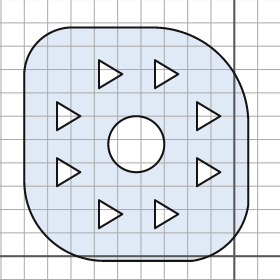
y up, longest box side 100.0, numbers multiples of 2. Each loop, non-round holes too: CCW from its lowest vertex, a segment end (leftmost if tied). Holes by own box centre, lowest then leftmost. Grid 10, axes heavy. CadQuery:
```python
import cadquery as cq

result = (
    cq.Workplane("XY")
    .moveTo(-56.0, -2.0)
    .lineTo(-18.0, -2.0)
    .threePointArc((-2.0, 6.0), (6.0, 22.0))
    .lineTo(6.0, 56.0)
    .threePointArc((-6.0, 86.0), (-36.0, 98.0))
    .lineTo(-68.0, 98.0)
    .threePointArc((-84.0, 92.0), (-90.0, 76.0))
    .lineTo(-90.0, 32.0)
    .threePointArc((-80.0, 8.0), (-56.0, -2.0))
    .close()
    .moveTo(-58.0, 12.0)
    .lineTo(-48.0, 18.0)
    .lineTo(-58.0, 24.0)
    .close()
    .moveTo(-34.0, 12.0)
    .lineTo(-24.0, 18.0)
    .lineTo(-34.0, 24.0)
    .close()
    .moveTo(-76.0, 30.0)
    .lineTo(-66.0, 36.0)
    .lineTo(-76.0, 42.0)
    .close()
    .moveTo(-16.0, 30.0)
    .lineTo(-6.0, 36.0)
    .lineTo(-16.0, 42.0)
    .close()
    .moveTo(-42.0, 48.0)
    .circle(12.0)
    .moveTo(-76.0, 54.0)
    .lineTo(-66.0, 60.0)
    .lineTo(-76.0, 66.0)
    .close()
    .moveTo(-16.0, 54.0)
    .lineTo(-6.0, 60.0)
    .lineTo(-16.0, 66.0)
    .close()
    .moveTo(-58.0, 72.0)
    .lineTo(-48.0, 78.0)
    .lineTo(-58.0, 84.0)
    .close()
    .moveTo(-34.0, 72.0)
    .lineTo(-24.0, 78.0)
    .lineTo(-34.0, 84.0)
    .close()
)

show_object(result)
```